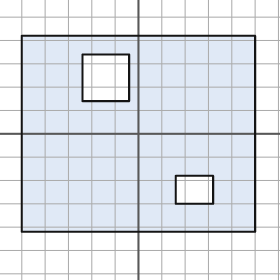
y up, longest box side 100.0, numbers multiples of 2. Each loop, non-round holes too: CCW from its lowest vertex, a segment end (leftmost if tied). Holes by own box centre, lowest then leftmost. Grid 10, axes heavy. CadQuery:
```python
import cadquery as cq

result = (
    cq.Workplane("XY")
    .moveTo(-50.0, -42.0)
    .lineTo(50.0, -42.0)
    .lineTo(50.0, 42.0)
    .lineTo(-50.0, 42.0)
    .close()
    .moveTo(16.0, -30.0)
    .lineTo(32.0, -30.0)
    .lineTo(32.0, -18.0)
    .lineTo(16.0, -18.0)
    .close()
    .moveTo(-24.0, 14.0)
    .lineTo(-4.0, 14.0)
    .lineTo(-4.0, 34.0)
    .lineTo(-24.0, 34.0)
    .close()
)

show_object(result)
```